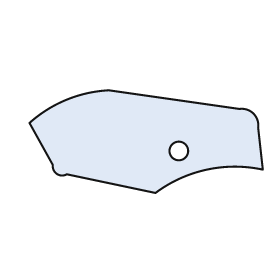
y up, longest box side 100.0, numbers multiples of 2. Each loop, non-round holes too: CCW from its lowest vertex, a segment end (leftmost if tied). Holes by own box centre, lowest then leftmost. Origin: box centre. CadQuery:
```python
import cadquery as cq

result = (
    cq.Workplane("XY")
    .moveTo(4.0, -22.0)
    .threePointArc((26.0, -12.0), (50.0, -12.0))
    .lineTo(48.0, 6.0)
    .threePointArc((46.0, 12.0), (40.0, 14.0))
    .lineTo(-16.0, 22.0)
    .threePointArc((-34.0, 18.0), (-50.0, 8.0))
    .lineTo(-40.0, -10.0)
    .threePointArc((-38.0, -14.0), (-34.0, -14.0))
    .close()
    .moveTo(14.0, -4.0)
    .circle(4.0)
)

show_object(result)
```